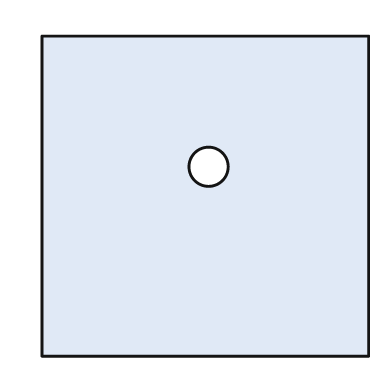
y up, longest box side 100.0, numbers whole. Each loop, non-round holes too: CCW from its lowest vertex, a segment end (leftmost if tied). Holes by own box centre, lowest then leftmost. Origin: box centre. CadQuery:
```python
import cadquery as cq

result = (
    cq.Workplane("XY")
    .moveTo(-50.0, -49.0)
    .lineTo(50.0, -49.0)
    .lineTo(50.0, 49.0)
    .lineTo(-50.0, 49.0)
    .close()
    .moveTo(1.0, 9.0)
    .circle(6.0)
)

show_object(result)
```